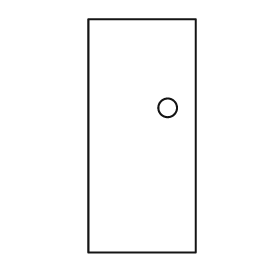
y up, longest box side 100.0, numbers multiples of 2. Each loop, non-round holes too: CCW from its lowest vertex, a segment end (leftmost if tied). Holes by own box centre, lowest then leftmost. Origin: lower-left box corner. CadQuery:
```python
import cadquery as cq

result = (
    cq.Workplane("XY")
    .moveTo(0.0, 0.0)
    .lineTo(46.0, 0.0)
    .lineTo(46.0, 100.0)
    .lineTo(0.0, 100.0)
    .close()
    .moveTo(34.0, 62.0)
    .circle(4.0)
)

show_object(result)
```